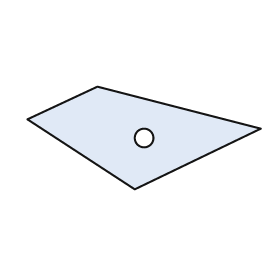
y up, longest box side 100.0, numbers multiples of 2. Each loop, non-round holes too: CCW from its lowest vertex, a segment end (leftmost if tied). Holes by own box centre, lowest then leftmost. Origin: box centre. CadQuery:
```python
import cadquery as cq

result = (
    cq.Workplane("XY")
    .moveTo(-4.0, -22.0)
    .lineTo(50.0, 4.0)
    .lineTo(-20.0, 22.0)
    .lineTo(-50.0, 8.0)
    .close()
    .moveTo(0.0, 0.0)
    .circle(4.0)
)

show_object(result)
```